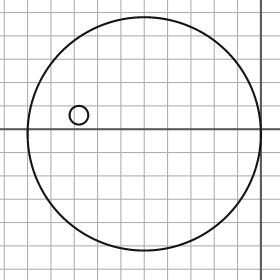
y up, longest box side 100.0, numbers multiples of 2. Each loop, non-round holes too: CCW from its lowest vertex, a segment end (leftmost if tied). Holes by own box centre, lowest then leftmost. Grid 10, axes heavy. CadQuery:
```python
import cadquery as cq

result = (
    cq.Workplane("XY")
    .moveTo(-50.0, -2.0)
    .circle(50.0)
    .moveTo(-78.0, 6.0)
    .circle(4.0)
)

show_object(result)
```